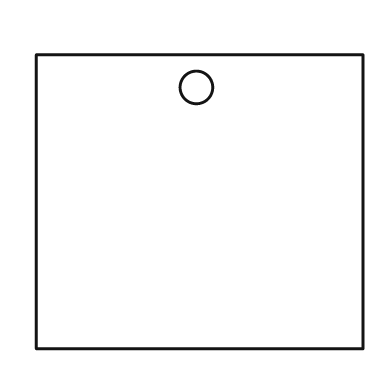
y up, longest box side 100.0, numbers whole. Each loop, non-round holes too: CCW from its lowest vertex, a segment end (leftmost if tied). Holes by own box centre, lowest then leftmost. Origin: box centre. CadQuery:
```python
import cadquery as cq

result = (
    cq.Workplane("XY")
    .moveTo(-50.0, -45.0)
    .lineTo(50.0, -45.0)
    .lineTo(50.0, 45.0)
    .lineTo(-50.0, 45.0)
    .close()
    .moveTo(-1.0, 35.0)
    .circle(5.0)
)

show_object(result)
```